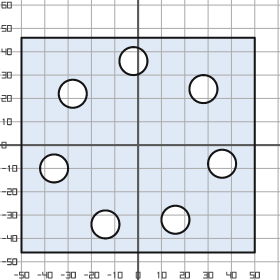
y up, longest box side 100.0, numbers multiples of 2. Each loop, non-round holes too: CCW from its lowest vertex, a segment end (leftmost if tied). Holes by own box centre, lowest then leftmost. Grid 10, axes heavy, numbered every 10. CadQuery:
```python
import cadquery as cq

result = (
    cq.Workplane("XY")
    .moveTo(-50.0, -46.0)
    .lineTo(50.0, -46.0)
    .lineTo(50.0, 46.0)
    .lineTo(-50.0, 46.0)
    .close()
    .moveTo(-14.0, -34.0)
    .circle(6.0)
    .moveTo(16.0, -32.0)
    .circle(6.0)
    .moveTo(-36.0, -10.0)
    .circle(6.0)
    .moveTo(36.0, -8.0)
    .circle(6.0)
    .moveTo(-28.0, 22.0)
    .circle(6.0)
    .moveTo(28.0, 24.0)
    .circle(6.0)
    .moveTo(-2.0, 36.0)
    .circle(6.0)
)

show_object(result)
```